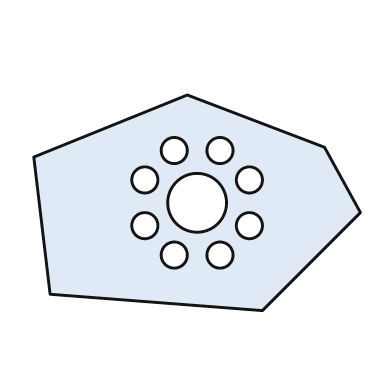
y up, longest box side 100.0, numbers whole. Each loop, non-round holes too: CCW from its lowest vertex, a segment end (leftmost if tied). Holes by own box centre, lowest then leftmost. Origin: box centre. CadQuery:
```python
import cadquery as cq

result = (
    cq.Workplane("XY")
    .moveTo(20.0, -33.0)
    .lineTo(50.0, -3.0)
    .lineTo(39.0, 17.0)
    .lineTo(-3.0, 33.0)
    .lineTo(-50.0, 14.0)
    .lineTo(-45.0, -28.0)
    .close()
    .moveTo(-7.0, -16.0)
    .circle(4.0)
    .moveTo(7.0, -16.0)
    .circle(4.0)
    .moveTo(-16.0, -7.0)
    .circle(4.0)
    .moveTo(16.0, -7.0)
    .circle(4.0)
    .moveTo(0.0, 0.0)
    .circle(9.0)
    .moveTo(-16.0, 7.0)
    .circle(4.0)
    .moveTo(16.0, 7.0)
    .circle(4.0)
    .moveTo(-7.0, 16.0)
    .circle(4.0)
    .moveTo(7.0, 16.0)
    .circle(4.0)
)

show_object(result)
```